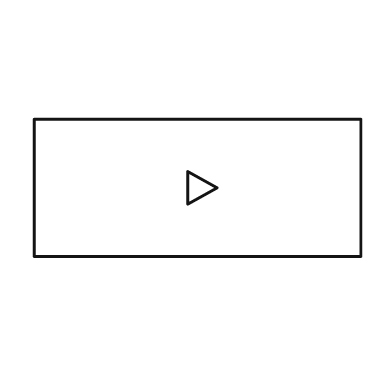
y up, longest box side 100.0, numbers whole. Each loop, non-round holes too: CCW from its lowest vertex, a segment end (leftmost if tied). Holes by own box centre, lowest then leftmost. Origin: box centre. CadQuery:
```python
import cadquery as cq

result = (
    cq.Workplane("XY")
    .moveTo(-50.0, -21.0)
    .lineTo(50.0, -21.0)
    .lineTo(50.0, 21.0)
    .lineTo(-50.0, 21.0)
    .close()
    .moveTo(-3.0, -5.0)
    .lineTo(6.0, 0.0)
    .lineTo(-3.0, 5.0)
    .close()
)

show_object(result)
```